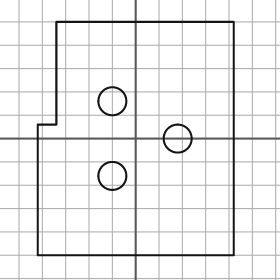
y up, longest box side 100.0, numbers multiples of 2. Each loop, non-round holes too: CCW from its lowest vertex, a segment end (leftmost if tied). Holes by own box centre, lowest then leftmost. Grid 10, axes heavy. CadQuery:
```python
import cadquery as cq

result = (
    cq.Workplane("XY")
    .moveTo(-42.0, -50.0)
    .lineTo(42.0, -50.0)
    .lineTo(42.0, 50.0)
    .lineTo(-34.0, 50.0)
    .lineTo(-34.0, 6.0)
    .lineTo(-42.0, 6.0)
    .close()
    .moveTo(-10.0, -16.0)
    .circle(6.0)
    .moveTo(18.0, 0.0)
    .circle(6.0)
    .moveTo(-10.0, 16.0)
    .circle(6.0)
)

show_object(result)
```